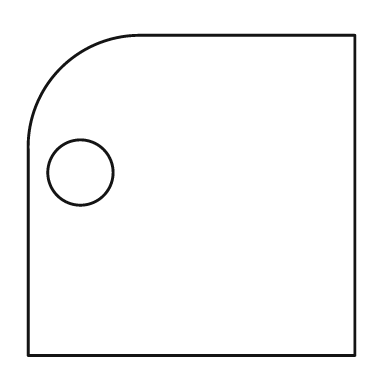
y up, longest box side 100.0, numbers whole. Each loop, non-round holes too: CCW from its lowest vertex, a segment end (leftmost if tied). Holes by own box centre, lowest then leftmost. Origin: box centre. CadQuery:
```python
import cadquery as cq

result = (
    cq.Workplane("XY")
    .moveTo(-50.0, -49.0)
    .lineTo(50.0, -49.0)
    .lineTo(50.0, 49.0)
    .lineTo(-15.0, 49.0)
    .threePointArc((-40.0, 39.0), (-50.0, 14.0))
    .close()
    .moveTo(-34.0, 7.0)
    .circle(10.0)
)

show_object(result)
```